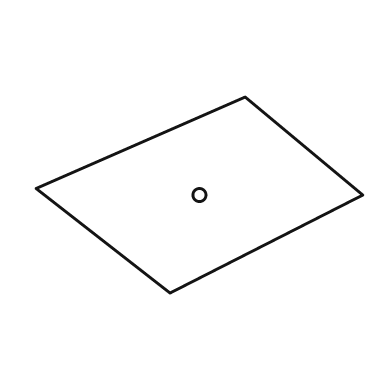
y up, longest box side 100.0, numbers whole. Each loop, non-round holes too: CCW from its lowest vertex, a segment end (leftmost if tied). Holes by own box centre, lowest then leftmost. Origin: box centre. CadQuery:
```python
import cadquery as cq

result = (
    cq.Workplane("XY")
    .moveTo(-9.0, -30.0)
    .lineTo(50.0, 0.0)
    .lineTo(14.0, 30.0)
    .lineTo(-50.0, 2.0)
    .close()
    .moveTo(0.0, 0.0)
    .circle(2.0)
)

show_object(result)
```